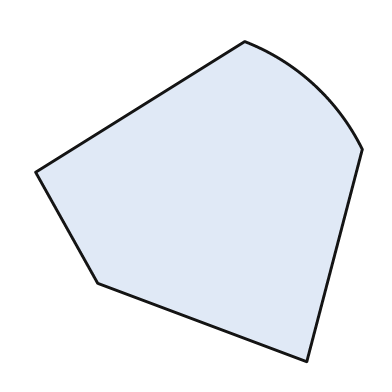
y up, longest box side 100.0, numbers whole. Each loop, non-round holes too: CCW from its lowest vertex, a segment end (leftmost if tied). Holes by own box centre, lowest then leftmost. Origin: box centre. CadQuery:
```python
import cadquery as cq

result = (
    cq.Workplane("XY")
    .moveTo(33.0, -49.0)
    .lineTo(50.0, 16.0)
    .threePointArc((35.0, 36.0), (14.0, 49.0))
    .lineTo(-50.0, 9.0)
    .lineTo(-31.0, -25.0)
    .close()
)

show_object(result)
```